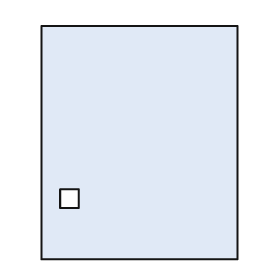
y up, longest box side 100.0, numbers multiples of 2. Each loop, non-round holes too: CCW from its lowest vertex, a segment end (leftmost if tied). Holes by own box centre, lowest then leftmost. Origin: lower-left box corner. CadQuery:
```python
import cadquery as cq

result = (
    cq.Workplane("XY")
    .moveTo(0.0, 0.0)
    .lineTo(84.0, 0.0)
    .lineTo(84.0, 100.0)
    .lineTo(0.0, 100.0)
    .close()
    .moveTo(8.0, 22.0)
    .lineTo(16.0, 22.0)
    .lineTo(16.0, 30.0)
    .lineTo(8.0, 30.0)
    .close()
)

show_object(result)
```